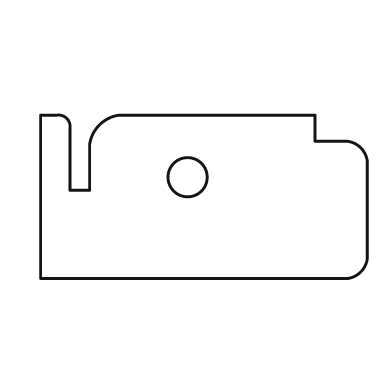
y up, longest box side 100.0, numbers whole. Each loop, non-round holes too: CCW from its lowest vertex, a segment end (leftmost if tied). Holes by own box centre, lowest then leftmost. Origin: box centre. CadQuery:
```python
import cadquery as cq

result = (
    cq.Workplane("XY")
    .moveTo(-50.0, -25.0)
    .lineTo(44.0, -25.0)
    .threePointArc((48.0, -23.0), (50.0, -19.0))
    .lineTo(50.0, 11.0)
    .threePointArc((48.0, 15.0), (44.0, 17.0))
    .lineTo(34.0, 17.0)
    .lineTo(34.0, 25.0)
    .lineTo(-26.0, 25.0)
    .threePointArc((-32.0, 22.0), (-35.0, 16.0))
    .lineTo(-35.0, 2.0)
    .lineTo(-41.0, 2.0)
    .lineTo(-41.0, 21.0)
    .threePointArc((-42.0, 24.0), (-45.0, 25.0))
    .lineTo(-50.0, 25.0)
    .close()
    .moveTo(-5.0, 6.0)
    .circle(6.0)
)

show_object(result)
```